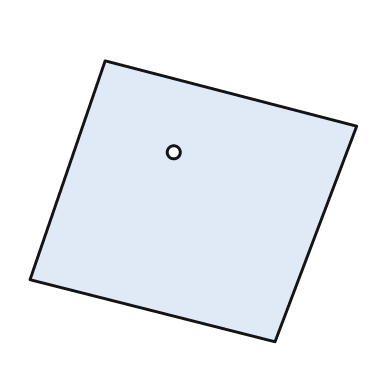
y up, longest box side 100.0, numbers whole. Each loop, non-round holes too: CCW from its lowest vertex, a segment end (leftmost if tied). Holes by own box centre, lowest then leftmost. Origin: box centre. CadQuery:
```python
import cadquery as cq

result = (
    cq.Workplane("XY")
    .moveTo(25.0, -43.0)
    .lineTo(50.0, 23.0)
    .lineTo(-27.0, 43.0)
    .lineTo(-50.0, -24.0)
    .close()
    .moveTo(-6.0, 15.0)
    .circle(2.0)
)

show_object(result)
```